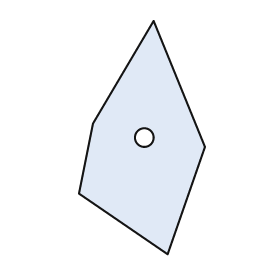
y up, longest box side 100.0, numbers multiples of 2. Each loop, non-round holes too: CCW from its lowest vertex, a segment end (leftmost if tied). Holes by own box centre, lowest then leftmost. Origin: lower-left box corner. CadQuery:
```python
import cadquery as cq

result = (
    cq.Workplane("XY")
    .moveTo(38.0, 0.0)
    .lineTo(54.0, 46.0)
    .lineTo(32.0, 100.0)
    .lineTo(6.0, 56.0)
    .lineTo(0.0, 26.0)
    .close()
    .moveTo(28.0, 50.0)
    .circle(4.0)
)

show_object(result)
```